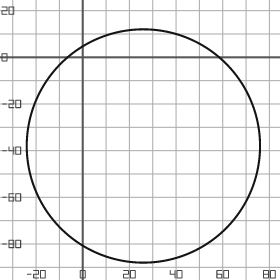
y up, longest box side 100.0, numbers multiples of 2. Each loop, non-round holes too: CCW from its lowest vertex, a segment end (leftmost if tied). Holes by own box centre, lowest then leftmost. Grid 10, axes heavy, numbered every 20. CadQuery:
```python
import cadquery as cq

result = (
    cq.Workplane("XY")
    .moveTo(26.0, -38.0)
    .circle(50.0)
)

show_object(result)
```